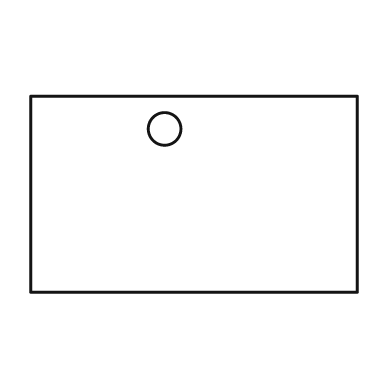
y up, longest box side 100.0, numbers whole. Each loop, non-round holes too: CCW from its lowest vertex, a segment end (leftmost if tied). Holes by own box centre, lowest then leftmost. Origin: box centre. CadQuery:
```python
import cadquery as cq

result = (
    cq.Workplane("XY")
    .moveTo(-50.0, -30.0)
    .lineTo(50.0, -30.0)
    .lineTo(50.0, 30.0)
    .lineTo(-50.0, 30.0)
    .close()
    .moveTo(-9.0, 20.0)
    .circle(5.0)
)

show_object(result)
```